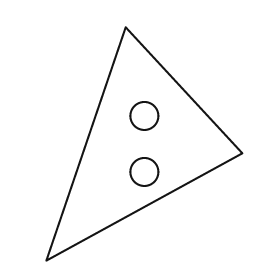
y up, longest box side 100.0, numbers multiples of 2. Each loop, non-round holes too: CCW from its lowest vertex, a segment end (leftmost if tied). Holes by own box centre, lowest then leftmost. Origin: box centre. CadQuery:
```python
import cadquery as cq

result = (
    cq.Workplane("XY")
    .moveTo(-42.0, -50.0)
    .lineTo(42.0, -4.0)
    .lineTo(-8.0, 50.0)
    .close()
    .moveTo(0.0, -12.0)
    .circle(6.0)
    .moveTo(0.0, 12.0)
    .circle(6.0)
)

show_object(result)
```